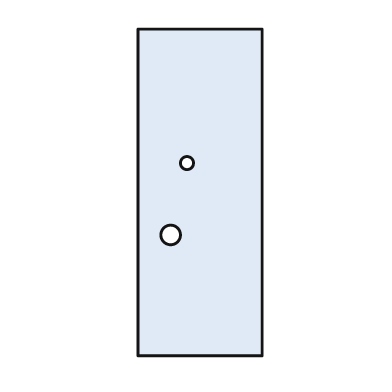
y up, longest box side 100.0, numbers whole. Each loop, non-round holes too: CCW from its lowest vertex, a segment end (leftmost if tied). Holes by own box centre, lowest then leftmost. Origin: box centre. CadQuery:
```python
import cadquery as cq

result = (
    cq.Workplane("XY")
    .moveTo(-19.0, -50.0)
    .lineTo(19.0, -50.0)
    .lineTo(19.0, 50.0)
    .lineTo(-19.0, 50.0)
    .close()
    .moveTo(-9.0, -13.0)
    .circle(3.0)
    .moveTo(-4.0, 9.0)
    .circle(2.0)
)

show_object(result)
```